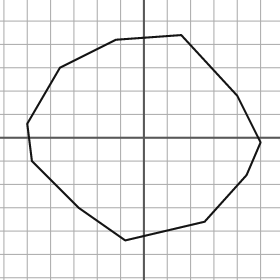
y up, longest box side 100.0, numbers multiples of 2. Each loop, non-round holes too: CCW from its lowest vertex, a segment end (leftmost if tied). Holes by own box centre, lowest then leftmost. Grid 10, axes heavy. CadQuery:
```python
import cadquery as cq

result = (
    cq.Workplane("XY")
    .moveTo(-8.0, -44.0)
    .lineTo(26.0, -36.0)
    .lineTo(44.0, -16.0)
    .lineTo(50.0, -2.0)
    .lineTo(40.0, 18.0)
    .lineTo(16.0, 44.0)
    .lineTo(-12.0, 42.0)
    .lineTo(-36.0, 30.0)
    .lineTo(-50.0, 6.0)
    .lineTo(-48.0, -10.0)
    .lineTo(-28.0, -30.0)
    .close()
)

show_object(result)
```